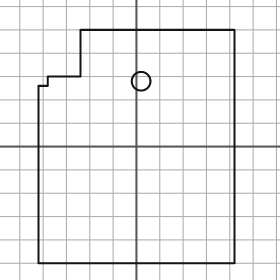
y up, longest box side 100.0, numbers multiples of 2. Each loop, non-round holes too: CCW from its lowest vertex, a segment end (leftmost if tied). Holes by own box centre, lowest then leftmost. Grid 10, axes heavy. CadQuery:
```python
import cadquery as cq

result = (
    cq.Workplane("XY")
    .moveTo(-42.0, -50.0)
    .lineTo(42.0, -50.0)
    .lineTo(42.0, 50.0)
    .lineTo(-24.0, 50.0)
    .lineTo(-24.0, 30.0)
    .lineTo(-38.0, 30.0)
    .lineTo(-38.0, 26.0)
    .lineTo(-42.0, 26.0)
    .close()
    .moveTo(2.0, 28.0)
    .circle(4.0)
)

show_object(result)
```